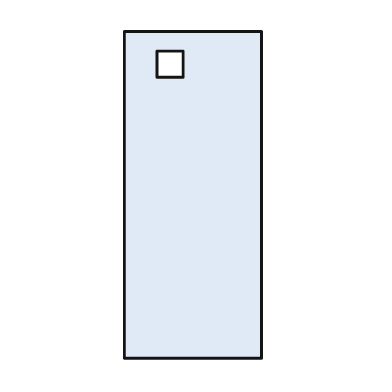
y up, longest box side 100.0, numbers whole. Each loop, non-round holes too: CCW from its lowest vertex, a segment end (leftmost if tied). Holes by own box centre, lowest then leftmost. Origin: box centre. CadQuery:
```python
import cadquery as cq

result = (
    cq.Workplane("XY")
    .moveTo(-21.0, -50.0)
    .lineTo(21.0, -50.0)
    .lineTo(21.0, 50.0)
    .lineTo(-21.0, 50.0)
    .close()
    .moveTo(-11.0, 36.0)
    .lineTo(-3.0, 36.0)
    .lineTo(-3.0, 44.0)
    .lineTo(-11.0, 44.0)
    .close()
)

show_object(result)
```